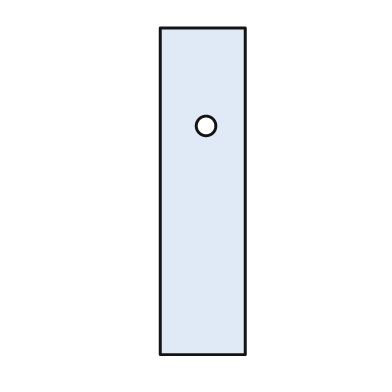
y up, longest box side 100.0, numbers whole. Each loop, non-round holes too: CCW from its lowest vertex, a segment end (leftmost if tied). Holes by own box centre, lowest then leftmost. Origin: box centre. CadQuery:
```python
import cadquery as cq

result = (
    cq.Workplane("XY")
    .moveTo(-13.0, -50.0)
    .lineTo(13.0, -50.0)
    .lineTo(13.0, 50.0)
    .lineTo(-13.0, 50.0)
    .close()
    .moveTo(1.0, 20.0)
    .circle(3.0)
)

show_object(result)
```